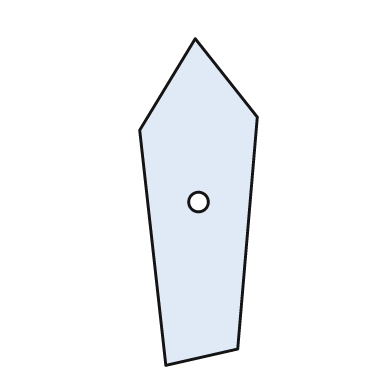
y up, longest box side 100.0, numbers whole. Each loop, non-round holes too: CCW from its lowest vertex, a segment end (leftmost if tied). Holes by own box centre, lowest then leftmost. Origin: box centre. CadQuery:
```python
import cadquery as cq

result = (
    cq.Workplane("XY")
    .moveTo(-10.0, -50.0)
    .lineTo(12.0, -45.0)
    .lineTo(18.0, 26.0)
    .lineTo(-1.0, 50.0)
    .lineTo(-18.0, 22.0)
    .close()
    .moveTo(0.0, 0.0)
    .circle(3.0)
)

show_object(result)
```